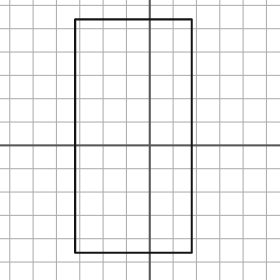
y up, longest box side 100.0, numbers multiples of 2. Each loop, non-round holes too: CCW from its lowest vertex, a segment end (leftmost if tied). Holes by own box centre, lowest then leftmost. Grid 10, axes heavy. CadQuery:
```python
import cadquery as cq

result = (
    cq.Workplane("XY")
    .moveTo(-32.0, -46.0)
    .lineTo(18.0, -46.0)
    .lineTo(18.0, 54.0)
    .lineTo(-32.0, 54.0)
    .close()
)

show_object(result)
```